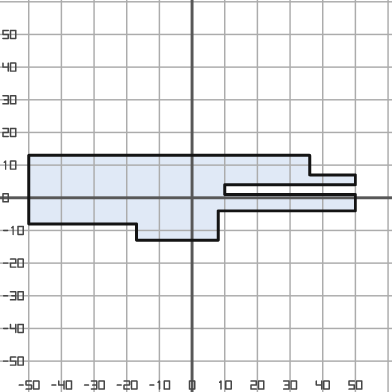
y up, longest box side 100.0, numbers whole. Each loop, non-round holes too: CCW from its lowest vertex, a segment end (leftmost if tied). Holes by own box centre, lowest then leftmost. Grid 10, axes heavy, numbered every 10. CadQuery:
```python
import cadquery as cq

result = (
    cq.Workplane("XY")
    .moveTo(-17.0, -13.0)
    .lineTo(8.0, -13.0)
    .lineTo(8.0, -4.0)
    .lineTo(50.0, -4.0)
    .lineTo(50.0, 1.0)
    .lineTo(10.0, 1.0)
    .lineTo(10.0, 4.0)
    .lineTo(50.0, 4.0)
    .lineTo(50.0, 7.0)
    .lineTo(36.0, 7.0)
    .lineTo(36.0, 13.0)
    .lineTo(-50.0, 13.0)
    .lineTo(-50.0, -8.0)
    .lineTo(-17.0, -8.0)
    .close()
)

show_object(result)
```